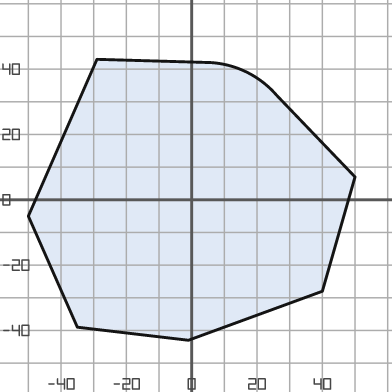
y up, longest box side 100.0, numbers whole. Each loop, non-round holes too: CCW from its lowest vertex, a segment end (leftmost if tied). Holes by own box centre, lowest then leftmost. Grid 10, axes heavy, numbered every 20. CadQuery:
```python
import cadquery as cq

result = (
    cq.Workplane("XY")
    .moveTo(-1.0, -43.0)
    .lineTo(40.0, -28.0)
    .lineTo(50.0, 7.0)
    .lineTo(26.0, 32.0)
    .threePointArc((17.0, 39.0), (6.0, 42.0))
    .lineTo(-29.0, 43.0)
    .lineTo(-50.0, -5.0)
    .lineTo(-35.0, -39.0)
    .close()
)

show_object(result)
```